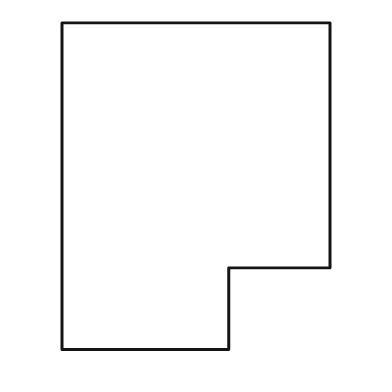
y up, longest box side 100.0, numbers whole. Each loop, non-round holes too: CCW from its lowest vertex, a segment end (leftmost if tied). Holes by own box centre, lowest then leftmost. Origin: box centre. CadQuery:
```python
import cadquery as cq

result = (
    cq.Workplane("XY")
    .moveTo(-41.0, -50.0)
    .lineTo(10.0, -50.0)
    .lineTo(10.0, -25.0)
    .lineTo(41.0, -25.0)
    .lineTo(41.0, 50.0)
    .lineTo(-41.0, 50.0)
    .close()
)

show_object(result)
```